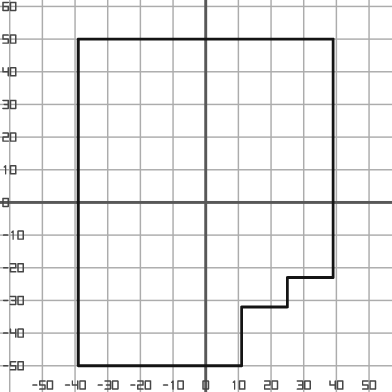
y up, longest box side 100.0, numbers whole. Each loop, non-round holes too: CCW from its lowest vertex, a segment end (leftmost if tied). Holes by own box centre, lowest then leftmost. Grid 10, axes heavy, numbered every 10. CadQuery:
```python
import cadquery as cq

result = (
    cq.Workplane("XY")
    .moveTo(-39.0, -50.0)
    .lineTo(11.0, -50.0)
    .lineTo(11.0, -32.0)
    .lineTo(25.0, -32.0)
    .lineTo(25.0, -23.0)
    .lineTo(39.0, -23.0)
    .lineTo(39.0, 50.0)
    .lineTo(-39.0, 50.0)
    .close()
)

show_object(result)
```